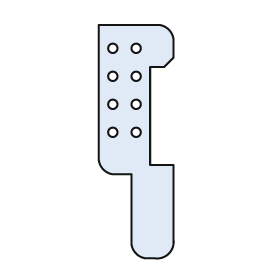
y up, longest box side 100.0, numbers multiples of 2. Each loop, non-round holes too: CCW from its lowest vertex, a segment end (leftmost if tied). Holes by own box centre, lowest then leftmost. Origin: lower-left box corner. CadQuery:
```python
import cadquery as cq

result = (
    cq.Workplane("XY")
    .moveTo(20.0, 0.0)
    .lineTo(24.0, 0.0)
    .threePointArc((30.0, 2.0), (32.0, 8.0))
    .lineTo(32.0, 40.0)
    .lineTo(22.0, 40.0)
    .lineTo(22.0, 82.0)
    .lineTo(28.0, 82.0)
    .lineTo(32.0, 86.0)
    .lineTo(32.0, 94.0)
    .threePointArc((30.0, 98.0), (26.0, 100.0))
    .lineTo(0.0, 100.0)
    .lineTo(0.0, 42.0)
    .threePointArc((2.0, 38.0), (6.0, 36.0))
    .lineTo(14.0, 36.0)
    .lineTo(14.0, 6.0)
    .threePointArc((16.0, 2.0), (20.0, 0.0))
    .close()
    .moveTo(6.0, 54.0)
    .circle(2.0)
    .moveTo(16.0, 54.0)
    .circle(2.0)
    .moveTo(6.0, 66.0)
    .circle(2.0)
    .moveTo(16.0, 66.0)
    .circle(2.0)
    .moveTo(6.0, 78.0)
    .circle(2.0)
    .moveTo(16.0, 78.0)
    .circle(2.0)
    .moveTo(6.0, 90.0)
    .circle(2.0)
    .moveTo(16.0, 90.0)
    .circle(2.0)
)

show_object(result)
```